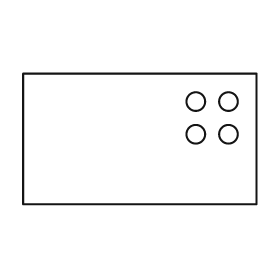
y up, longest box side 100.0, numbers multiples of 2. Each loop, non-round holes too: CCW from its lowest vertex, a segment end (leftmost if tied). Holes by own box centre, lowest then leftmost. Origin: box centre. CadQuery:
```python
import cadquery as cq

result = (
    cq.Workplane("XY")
    .moveTo(-50.0, -28.0)
    .lineTo(50.0, -28.0)
    .lineTo(50.0, 28.0)
    .lineTo(-50.0, 28.0)
    .close()
    .moveTo(24.0, 2.0)
    .circle(4.0)
    .moveTo(38.0, 2.0)
    .circle(4.0)
    .moveTo(24.0, 16.0)
    .circle(4.0)
    .moveTo(38.0, 16.0)
    .circle(4.0)
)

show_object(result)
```